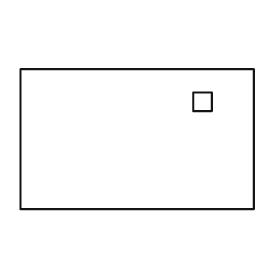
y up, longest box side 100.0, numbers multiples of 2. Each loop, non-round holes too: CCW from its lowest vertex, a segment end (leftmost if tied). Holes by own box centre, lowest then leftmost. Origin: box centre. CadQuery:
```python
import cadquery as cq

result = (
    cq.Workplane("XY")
    .moveTo(-50.0, -30.0)
    .lineTo(50.0, -30.0)
    .lineTo(50.0, 30.0)
    .lineTo(-50.0, 30.0)
    .close()
    .moveTo(24.0, 12.0)
    .lineTo(32.0, 12.0)
    .lineTo(32.0, 20.0)
    .lineTo(24.0, 20.0)
    .close()
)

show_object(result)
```